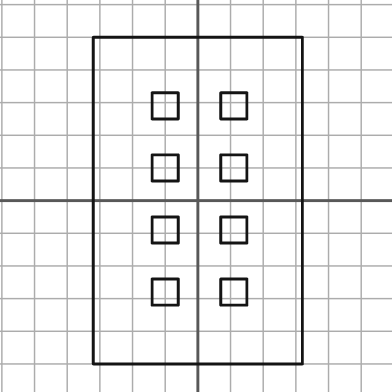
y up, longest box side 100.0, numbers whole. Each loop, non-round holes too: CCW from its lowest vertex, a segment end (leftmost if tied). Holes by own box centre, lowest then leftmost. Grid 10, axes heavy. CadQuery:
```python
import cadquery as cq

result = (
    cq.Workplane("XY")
    .moveTo(-32.0, -50.0)
    .lineTo(32.0, -50.0)
    .lineTo(32.0, 50.0)
    .lineTo(-32.0, 50.0)
    .close()
    .moveTo(-14.0, -32.0)
    .lineTo(-6.0, -32.0)
    .lineTo(-6.0, -24.0)
    .lineTo(-14.0, -24.0)
    .close()
    .moveTo(7.0, -32.0)
    .lineTo(15.0, -32.0)
    .lineTo(15.0, -24.0)
    .lineTo(7.0, -24.0)
    .close()
    .moveTo(-14.0, -13.0)
    .lineTo(-6.0, -13.0)
    .lineTo(-6.0, -5.0)
    .lineTo(-14.0, -5.0)
    .close()
    .moveTo(7.0, -13.0)
    .lineTo(15.0, -13.0)
    .lineTo(15.0, -5.0)
    .lineTo(7.0, -5.0)
    .close()
    .moveTo(-14.0, 6.0)
    .lineTo(-6.0, 6.0)
    .lineTo(-6.0, 14.0)
    .lineTo(-14.0, 14.0)
    .close()
    .moveTo(7.0, 6.0)
    .lineTo(15.0, 6.0)
    .lineTo(15.0, 14.0)
    .lineTo(7.0, 14.0)
    .close()
    .moveTo(-14.0, 25.0)
    .lineTo(-6.0, 25.0)
    .lineTo(-6.0, 33.0)
    .lineTo(-14.0, 33.0)
    .close()
    .moveTo(7.0, 25.0)
    .lineTo(15.0, 25.0)
    .lineTo(15.0, 33.0)
    .lineTo(7.0, 33.0)
    .close()
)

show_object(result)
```